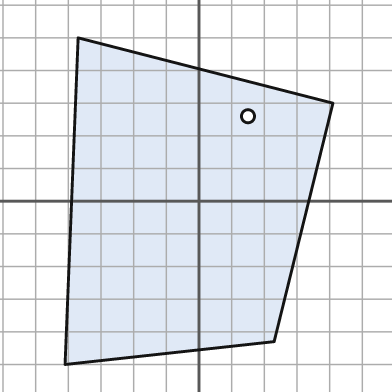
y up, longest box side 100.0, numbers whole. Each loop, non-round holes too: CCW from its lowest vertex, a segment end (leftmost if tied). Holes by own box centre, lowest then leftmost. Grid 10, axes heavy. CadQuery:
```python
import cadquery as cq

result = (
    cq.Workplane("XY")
    .moveTo(-41.0, -50.0)
    .lineTo(23.0, -43.0)
    .lineTo(41.0, 30.0)
    .lineTo(-37.0, 50.0)
    .close()
    .moveTo(15.0, 26.0)
    .circle(2.0)
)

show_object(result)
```